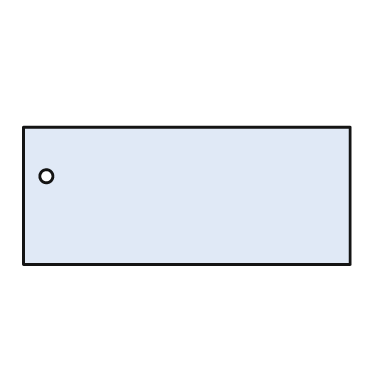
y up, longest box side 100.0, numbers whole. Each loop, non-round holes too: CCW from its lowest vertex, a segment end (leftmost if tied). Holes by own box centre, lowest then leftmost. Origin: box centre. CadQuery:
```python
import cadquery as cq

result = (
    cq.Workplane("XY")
    .moveTo(-50.0, -21.0)
    .lineTo(50.0, -21.0)
    .lineTo(50.0, 21.0)
    .lineTo(-50.0, 21.0)
    .close()
    .moveTo(-43.0, 6.0)
    .circle(2.0)
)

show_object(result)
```